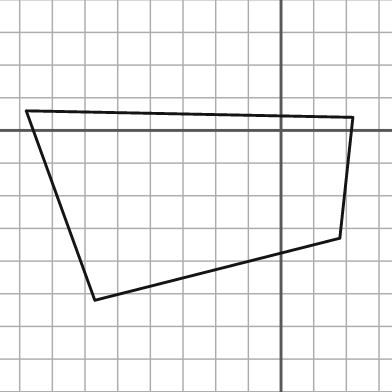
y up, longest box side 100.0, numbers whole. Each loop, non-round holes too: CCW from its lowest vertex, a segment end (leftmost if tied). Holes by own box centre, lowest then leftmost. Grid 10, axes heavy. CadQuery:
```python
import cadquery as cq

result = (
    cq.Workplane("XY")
    .moveTo(-57.0, -52.0)
    .lineTo(18.0, -33.0)
    .lineTo(22.0, 4.0)
    .lineTo(-78.0, 6.0)
    .close()
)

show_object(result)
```